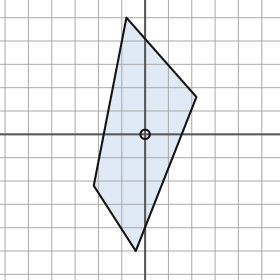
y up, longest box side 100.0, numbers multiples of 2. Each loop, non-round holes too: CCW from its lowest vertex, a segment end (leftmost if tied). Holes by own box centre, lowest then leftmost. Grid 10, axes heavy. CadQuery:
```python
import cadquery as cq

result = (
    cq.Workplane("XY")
    .moveTo(-4.0, -50.0)
    .lineTo(22.0, 16.0)
    .lineTo(-8.0, 50.0)
    .lineTo(-22.0, -22.0)
    .close()
    .moveTo(0.0, 0.0)
    .circle(2.0)
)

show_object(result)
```